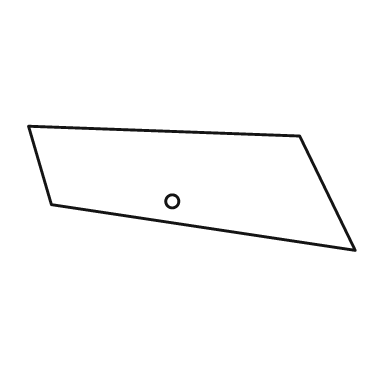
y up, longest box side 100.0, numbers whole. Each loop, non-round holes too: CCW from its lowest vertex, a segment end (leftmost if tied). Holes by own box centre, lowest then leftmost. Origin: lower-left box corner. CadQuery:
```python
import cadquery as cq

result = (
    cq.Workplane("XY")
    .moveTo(100.0, 0.0)
    .lineTo(83.0, 35.0)
    .lineTo(0.0, 38.0)
    .lineTo(7.0, 14.0)
    .close()
    .moveTo(44.0, 15.0)
    .circle(2.0)
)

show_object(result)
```